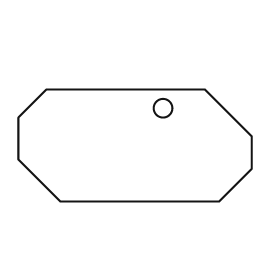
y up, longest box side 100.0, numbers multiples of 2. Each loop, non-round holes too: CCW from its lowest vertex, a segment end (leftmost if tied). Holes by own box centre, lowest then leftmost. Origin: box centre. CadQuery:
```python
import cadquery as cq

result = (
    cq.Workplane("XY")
    .moveTo(-32.0, -24.0)
    .lineTo(36.0, -24.0)
    .lineTo(50.0, -10.0)
    .lineTo(50.0, 4.0)
    .lineTo(30.0, 24.0)
    .lineTo(-38.0, 24.0)
    .lineTo(-50.0, 12.0)
    .lineTo(-50.0, -6.0)
    .close()
    .moveTo(12.0, 16.0)
    .circle(4.0)
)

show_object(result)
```